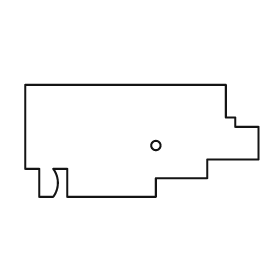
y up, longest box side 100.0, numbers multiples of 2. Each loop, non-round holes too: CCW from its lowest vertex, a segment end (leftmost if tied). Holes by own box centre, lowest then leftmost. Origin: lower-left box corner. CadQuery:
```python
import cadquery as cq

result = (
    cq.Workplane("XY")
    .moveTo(6.0, 0.0)
    .lineTo(12.0, 0.0)
    .threePointArc((14.0, 6.0), (12.0, 12.0))
    .lineTo(18.0, 12.0)
    .lineTo(18.0, 0.0)
    .lineTo(56.0, 0.0)
    .lineTo(56.0, 8.0)
    .lineTo(78.0, 8.0)
    .lineTo(78.0, 16.0)
    .lineTo(100.0, 16.0)
    .lineTo(100.0, 30.0)
    .lineTo(90.0, 30.0)
    .lineTo(90.0, 34.0)
    .lineTo(86.0, 34.0)
    .lineTo(86.0, 48.0)
    .lineTo(0.0, 48.0)
    .lineTo(0.0, 12.0)
    .lineTo(6.0, 12.0)
    .close()
    .moveTo(56.0, 22.0)
    .circle(2.0)
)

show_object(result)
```